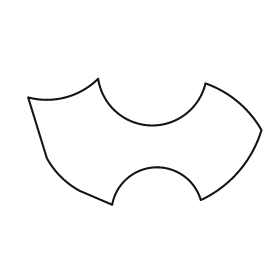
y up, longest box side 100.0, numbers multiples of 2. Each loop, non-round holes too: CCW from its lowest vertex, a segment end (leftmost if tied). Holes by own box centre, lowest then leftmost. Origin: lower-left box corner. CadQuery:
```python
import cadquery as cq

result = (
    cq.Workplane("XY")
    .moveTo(36.0, 0.0)
    .threePointArc((54.0, 16.0), (74.0, 2.0))
    .threePointArc((90.0, 14.0), (100.0, 32.0))
    .threePointArc((90.0, 44.0), (76.0, 52.0))
    .threePointArc((52.0, 34.0), (30.0, 54.0))
    .threePointArc((16.0, 46.0), (0.0, 46.0))
    .lineTo(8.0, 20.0)
    .threePointArc((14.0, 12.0), (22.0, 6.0))
    .close()
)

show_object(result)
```